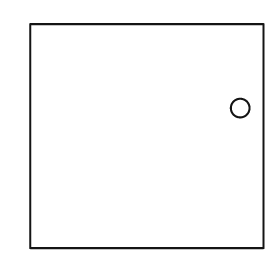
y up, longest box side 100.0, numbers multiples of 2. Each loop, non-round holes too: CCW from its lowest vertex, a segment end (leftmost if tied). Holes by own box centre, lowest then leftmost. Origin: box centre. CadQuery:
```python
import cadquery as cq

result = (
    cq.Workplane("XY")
    .moveTo(-50.0, -48.0)
    .lineTo(50.0, -48.0)
    .lineTo(50.0, 48.0)
    .lineTo(-50.0, 48.0)
    .close()
    .moveTo(40.0, 12.0)
    .circle(4.0)
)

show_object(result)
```